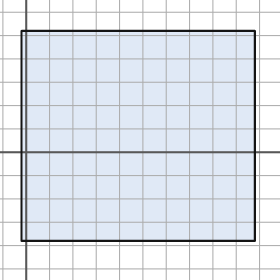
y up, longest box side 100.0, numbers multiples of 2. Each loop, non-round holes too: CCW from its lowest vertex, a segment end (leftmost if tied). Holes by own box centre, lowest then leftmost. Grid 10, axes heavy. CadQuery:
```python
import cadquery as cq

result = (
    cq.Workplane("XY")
    .moveTo(-2.0, -38.0)
    .lineTo(98.0, -38.0)
    .lineTo(98.0, 52.0)
    .lineTo(-2.0, 52.0)
    .close()
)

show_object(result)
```